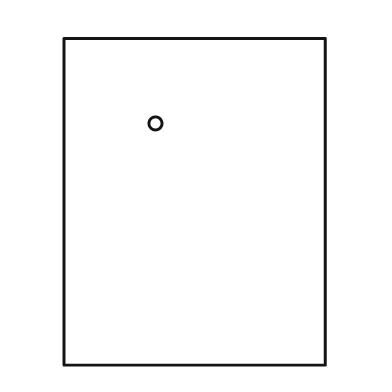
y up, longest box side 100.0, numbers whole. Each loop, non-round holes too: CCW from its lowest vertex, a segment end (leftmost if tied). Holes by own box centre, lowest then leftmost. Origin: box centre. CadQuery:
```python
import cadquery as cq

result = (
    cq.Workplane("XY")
    .moveTo(-40.0, -50.0)
    .lineTo(40.0, -50.0)
    .lineTo(40.0, 50.0)
    .lineTo(-40.0, 50.0)
    .close()
    .moveTo(-12.0, 24.0)
    .circle(2.0)
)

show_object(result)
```